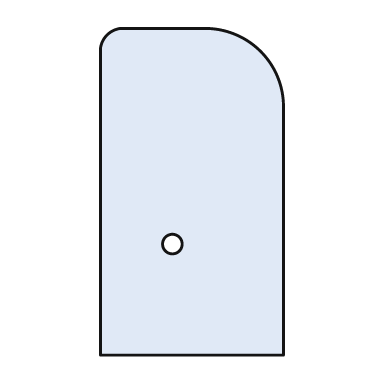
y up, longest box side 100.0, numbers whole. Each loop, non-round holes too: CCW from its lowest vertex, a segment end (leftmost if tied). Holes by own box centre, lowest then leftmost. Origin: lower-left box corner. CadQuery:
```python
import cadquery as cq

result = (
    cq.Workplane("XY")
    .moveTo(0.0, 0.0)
    .lineTo(56.0, 0.0)
    .lineTo(56.0, 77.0)
    .threePointArc((49.0, 93.0), (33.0, 100.0))
    .lineTo(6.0, 100.0)
    .threePointArc((2.0, 98.0), (0.0, 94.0))
    .close()
    .moveTo(22.0, 34.0)
    .circle(3.0)
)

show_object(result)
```